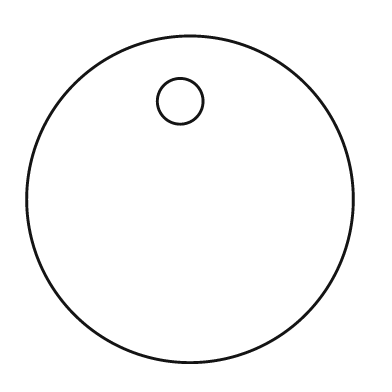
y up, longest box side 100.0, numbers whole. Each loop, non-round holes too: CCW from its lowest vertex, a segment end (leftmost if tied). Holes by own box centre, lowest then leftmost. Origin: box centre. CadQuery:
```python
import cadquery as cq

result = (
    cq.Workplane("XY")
    .moveTo(0.0, 0.0)
    .circle(50.0)
    .moveTo(-3.0, 30.0)
    .circle(7.0)
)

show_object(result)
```